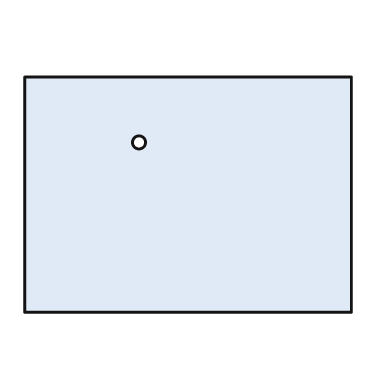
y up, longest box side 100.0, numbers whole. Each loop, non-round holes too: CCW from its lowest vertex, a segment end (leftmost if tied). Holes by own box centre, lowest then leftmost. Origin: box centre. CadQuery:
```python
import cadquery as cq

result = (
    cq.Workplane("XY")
    .moveTo(-50.0, -36.0)
    .lineTo(50.0, -36.0)
    .lineTo(50.0, 36.0)
    .lineTo(-50.0, 36.0)
    .close()
    .moveTo(-15.0, 16.0)
    .circle(2.0)
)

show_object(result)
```